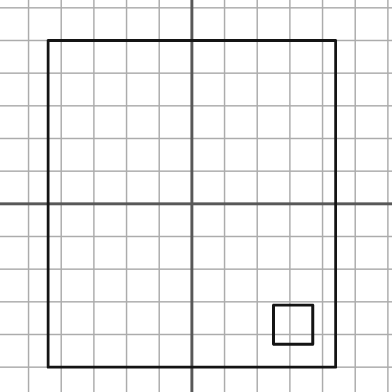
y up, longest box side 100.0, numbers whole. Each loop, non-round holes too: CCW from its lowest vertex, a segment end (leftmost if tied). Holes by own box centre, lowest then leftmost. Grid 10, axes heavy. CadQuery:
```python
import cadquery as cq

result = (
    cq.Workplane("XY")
    .moveTo(-44.0, -50.0)
    .lineTo(44.0, -50.0)
    .lineTo(44.0, 50.0)
    .lineTo(-44.0, 50.0)
    .close()
    .moveTo(25.0, -43.0)
    .lineTo(37.0, -43.0)
    .lineTo(37.0, -31.0)
    .lineTo(25.0, -31.0)
    .close()
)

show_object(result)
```